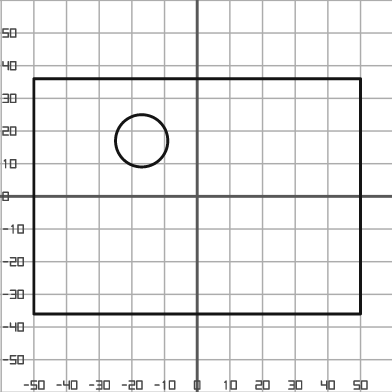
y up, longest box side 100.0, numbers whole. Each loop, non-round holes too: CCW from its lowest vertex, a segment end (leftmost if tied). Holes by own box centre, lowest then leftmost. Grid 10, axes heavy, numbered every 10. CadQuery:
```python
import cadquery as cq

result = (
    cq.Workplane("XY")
    .moveTo(-50.0, -36.0)
    .lineTo(50.0, -36.0)
    .lineTo(50.0, 36.0)
    .lineTo(-50.0, 36.0)
    .close()
    .moveTo(-17.0, 17.0)
    .circle(8.0)
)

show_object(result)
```